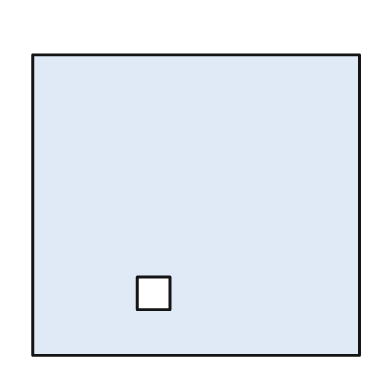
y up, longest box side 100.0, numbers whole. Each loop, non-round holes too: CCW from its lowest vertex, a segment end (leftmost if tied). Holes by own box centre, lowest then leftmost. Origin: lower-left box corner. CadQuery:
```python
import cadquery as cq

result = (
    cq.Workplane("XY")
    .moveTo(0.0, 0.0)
    .lineTo(100.0, 0.0)
    .lineTo(100.0, 92.0)
    .lineTo(0.0, 92.0)
    .close()
    .moveTo(32.0, 14.0)
    .lineTo(42.0, 14.0)
    .lineTo(42.0, 24.0)
    .lineTo(32.0, 24.0)
    .close()
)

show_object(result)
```